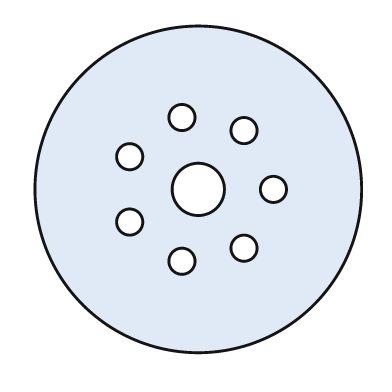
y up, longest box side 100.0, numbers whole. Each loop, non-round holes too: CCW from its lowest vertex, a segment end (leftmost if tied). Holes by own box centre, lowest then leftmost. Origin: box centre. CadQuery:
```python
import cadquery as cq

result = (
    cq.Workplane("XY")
    .moveTo(0.0, 0.0)
    .circle(50.0)
    .moveTo(-5.0, -22.0)
    .circle(4.0)
    .moveTo(14.0, -18.0)
    .circle(4.0)
    .moveTo(-21.0, -10.0)
    .circle(4.0)
    .moveTo(0.0, 0.0)
    .circle(8.0)
    .moveTo(23.0, 0.0)
    .circle(4.0)
    .moveTo(-21.0, 10.0)
    .circle(4.0)
    .moveTo(14.0, 18.0)
    .circle(4.0)
    .moveTo(-5.0, 22.0)
    .circle(4.0)
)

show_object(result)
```